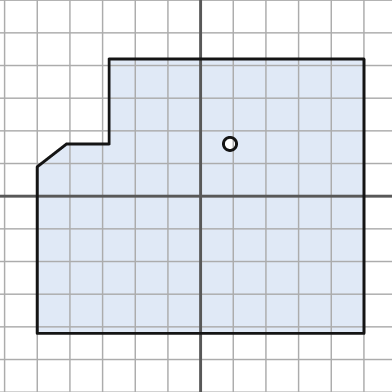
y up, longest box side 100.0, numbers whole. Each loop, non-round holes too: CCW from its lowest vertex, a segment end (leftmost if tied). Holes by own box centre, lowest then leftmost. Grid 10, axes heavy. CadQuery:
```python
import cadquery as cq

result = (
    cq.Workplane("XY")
    .moveTo(-50.0, -42.0)
    .lineTo(50.0, -42.0)
    .lineTo(50.0, 42.0)
    .lineTo(-28.0, 42.0)
    .lineTo(-28.0, 16.0)
    .lineTo(-41.0, 16.0)
    .lineTo(-50.0, 9.0)
    .close()
    .moveTo(9.0, 16.0)
    .circle(2.0)
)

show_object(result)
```